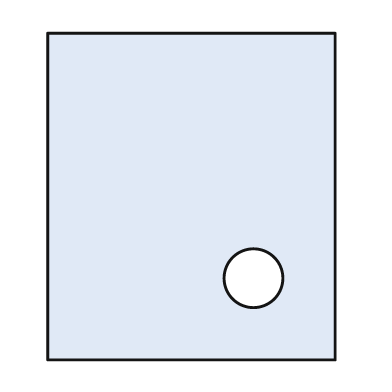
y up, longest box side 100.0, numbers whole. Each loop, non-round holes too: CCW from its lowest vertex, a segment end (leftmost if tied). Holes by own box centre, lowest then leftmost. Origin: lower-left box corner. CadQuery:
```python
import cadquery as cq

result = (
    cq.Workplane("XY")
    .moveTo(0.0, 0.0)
    .lineTo(88.0, 0.0)
    .lineTo(88.0, 100.0)
    .lineTo(0.0, 100.0)
    .close()
    .moveTo(63.0, 25.0)
    .circle(9.0)
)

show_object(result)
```